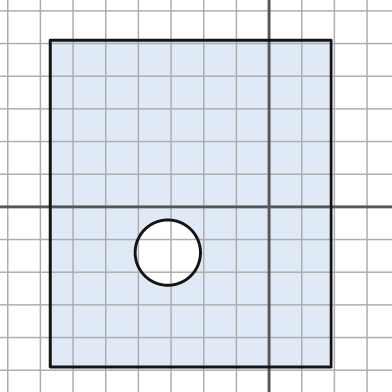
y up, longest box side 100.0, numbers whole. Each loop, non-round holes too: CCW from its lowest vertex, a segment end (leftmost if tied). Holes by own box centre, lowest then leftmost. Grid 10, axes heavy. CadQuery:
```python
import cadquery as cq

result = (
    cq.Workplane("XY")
    .moveTo(-67.0, -49.0)
    .lineTo(19.0, -49.0)
    .lineTo(19.0, 51.0)
    .lineTo(-67.0, 51.0)
    .close()
    .moveTo(-31.0, -14.0)
    .circle(10.0)
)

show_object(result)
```